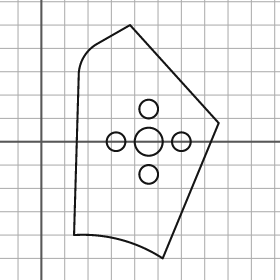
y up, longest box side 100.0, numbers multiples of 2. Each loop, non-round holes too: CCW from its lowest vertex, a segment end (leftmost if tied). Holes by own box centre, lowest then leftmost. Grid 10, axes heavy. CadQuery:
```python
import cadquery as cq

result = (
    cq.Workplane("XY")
    .moveTo(52.0, -50.0)
    .lineTo(76.0, 8.0)
    .lineTo(38.0, 50.0)
    .lineTo(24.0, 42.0)
    .threePointArc((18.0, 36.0), (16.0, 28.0))
    .lineTo(14.0, -40.0)
    .threePointArc((34.0, -42.0), (52.0, -50.0))
    .close()
    .moveTo(46.0, -14.0)
    .circle(4.0)
    .moveTo(32.0, 0.0)
    .circle(4.0)
    .moveTo(46.0, 0.0)
    .circle(6.0)
    .moveTo(60.0, 0.0)
    .circle(4.0)
    .moveTo(46.0, 14.0)
    .circle(4.0)
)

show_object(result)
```